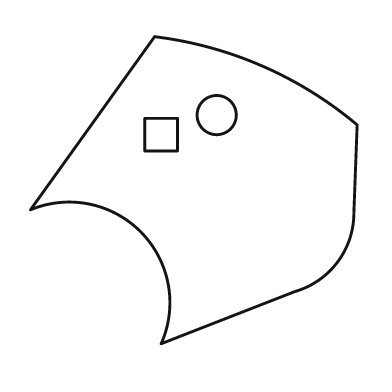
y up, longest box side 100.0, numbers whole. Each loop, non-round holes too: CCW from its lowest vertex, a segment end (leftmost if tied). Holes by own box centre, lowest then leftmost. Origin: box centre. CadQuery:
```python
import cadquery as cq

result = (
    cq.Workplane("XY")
    .moveTo(-10.0, -47.0)
    .lineTo(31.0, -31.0)
    .threePointArc((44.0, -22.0), (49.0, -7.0))
    .lineTo(50.0, 20.0)
    .threePointArc((21.0, 38.0), (-12.0, 47.0))
    .lineTo(-50.0, -6.0)
    .threePointArc((-16.0, -13.0), (-10.0, -47.0))
    .close()
    .moveTo(-15.0, 12.0)
    .lineTo(-5.0, 12.0)
    .lineTo(-5.0, 22.0)
    .lineTo(-15.0, 22.0)
    .close()
    .moveTo(7.0, 23.0)
    .circle(6.0)
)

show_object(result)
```